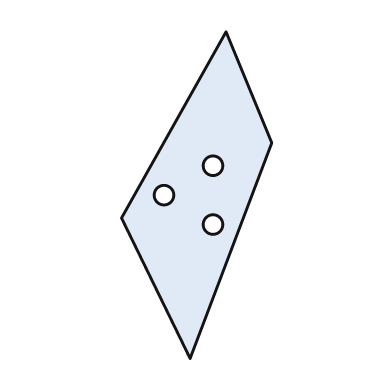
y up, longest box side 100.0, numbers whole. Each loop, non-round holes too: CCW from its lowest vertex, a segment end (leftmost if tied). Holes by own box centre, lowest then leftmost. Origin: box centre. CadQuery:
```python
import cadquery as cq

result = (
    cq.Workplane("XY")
    .moveTo(-2.0, -50.0)
    .lineTo(23.0, 16.0)
    .lineTo(9.0, 50.0)
    .lineTo(-23.0, -7.0)
    .close()
    .moveTo(5.0, -9.0)
    .circle(3.0)
    .moveTo(-10.0, 0.0)
    .circle(3.0)
    .moveTo(5.0, 9.0)
    .circle(3.0)
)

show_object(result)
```